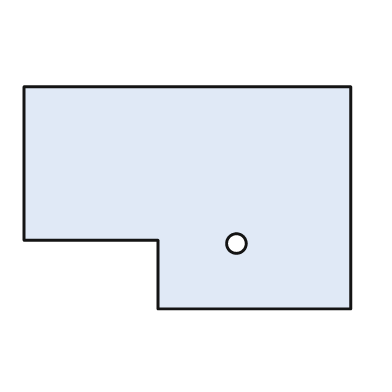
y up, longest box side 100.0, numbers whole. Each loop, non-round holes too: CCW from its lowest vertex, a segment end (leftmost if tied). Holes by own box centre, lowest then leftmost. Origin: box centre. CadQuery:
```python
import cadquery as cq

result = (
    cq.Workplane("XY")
    .moveTo(-9.0, -34.0)
    .lineTo(50.0, -34.0)
    .lineTo(50.0, 34.0)
    .lineTo(-50.0, 34.0)
    .lineTo(-50.0, -13.0)
    .lineTo(-9.0, -13.0)
    .close()
    .moveTo(15.0, -14.0)
    .circle(3.0)
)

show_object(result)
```